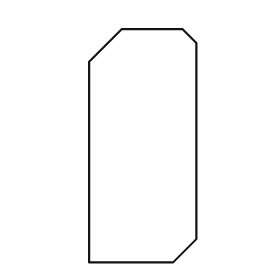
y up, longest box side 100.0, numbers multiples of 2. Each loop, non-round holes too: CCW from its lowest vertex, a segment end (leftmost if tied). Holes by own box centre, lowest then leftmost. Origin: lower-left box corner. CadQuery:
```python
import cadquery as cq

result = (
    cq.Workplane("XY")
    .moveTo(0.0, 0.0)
    .lineTo(36.0, 0.0)
    .lineTo(46.0, 10.0)
    .lineTo(46.0, 94.0)
    .lineTo(40.0, 100.0)
    .lineTo(14.0, 100.0)
    .lineTo(0.0, 86.0)
    .close()
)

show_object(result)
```